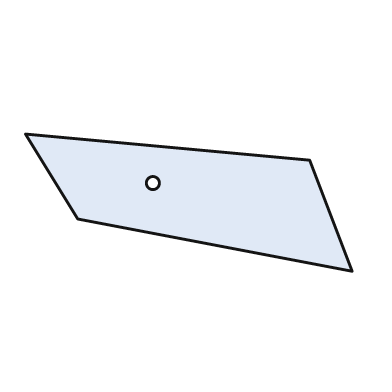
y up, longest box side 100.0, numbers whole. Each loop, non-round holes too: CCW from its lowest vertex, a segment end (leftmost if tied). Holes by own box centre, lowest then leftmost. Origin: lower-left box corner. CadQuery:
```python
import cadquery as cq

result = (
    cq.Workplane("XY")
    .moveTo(100.0, 0.0)
    .lineTo(87.0, 34.0)
    .lineTo(0.0, 42.0)
    .lineTo(16.0, 16.0)
    .close()
    .moveTo(39.0, 27.0)
    .circle(2.0)
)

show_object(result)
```